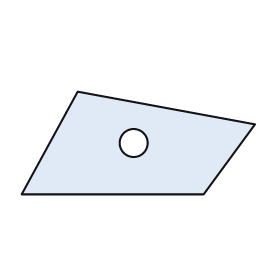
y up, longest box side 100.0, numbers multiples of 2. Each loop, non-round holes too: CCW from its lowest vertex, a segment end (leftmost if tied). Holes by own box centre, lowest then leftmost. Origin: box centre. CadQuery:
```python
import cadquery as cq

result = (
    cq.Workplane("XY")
    .moveTo(-50.0, -22.0)
    .lineTo(28.0, -22.0)
    .lineTo(50.0, 8.0)
    .lineTo(-26.0, 22.0)
    .close()
    .moveTo(-2.0, 0.0)
    .circle(6.0)
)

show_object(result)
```